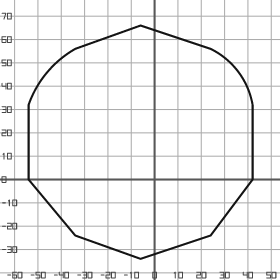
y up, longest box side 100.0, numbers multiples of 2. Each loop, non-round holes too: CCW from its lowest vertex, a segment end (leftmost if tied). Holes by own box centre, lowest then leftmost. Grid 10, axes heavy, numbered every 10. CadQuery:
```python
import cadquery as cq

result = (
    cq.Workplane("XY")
    .moveTo(-6.0, -34.0)
    .lineTo(24.0, -24.0)
    .lineTo(42.0, 0.0)
    .lineTo(42.0, 32.0)
    .threePointArc((36.0, 46.0), (24.0, 56.0))
    .lineTo(-6.0, 66.0)
    .lineTo(-34.0, 56.0)
    .threePointArc((-46.0, 46.0), (-54.0, 32.0))
    .lineTo(-54.0, 0.0)
    .lineTo(-34.0, -24.0)
    .close()
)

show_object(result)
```